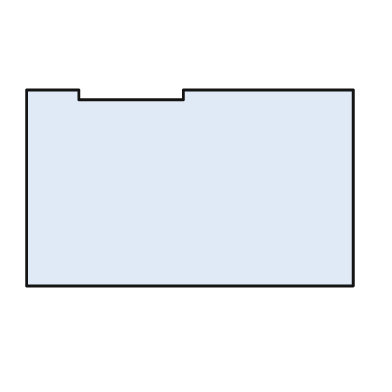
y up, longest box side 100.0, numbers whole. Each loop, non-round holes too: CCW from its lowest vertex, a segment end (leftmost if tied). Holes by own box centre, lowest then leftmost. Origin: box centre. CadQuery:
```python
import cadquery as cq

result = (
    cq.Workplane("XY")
    .moveTo(-50.0, -30.0)
    .lineTo(50.0, -30.0)
    .lineTo(50.0, 30.0)
    .lineTo(-2.0, 30.0)
    .lineTo(-2.0, 27.0)
    .lineTo(-34.0, 27.0)
    .lineTo(-34.0, 30.0)
    .lineTo(-50.0, 30.0)
    .close()
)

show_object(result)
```